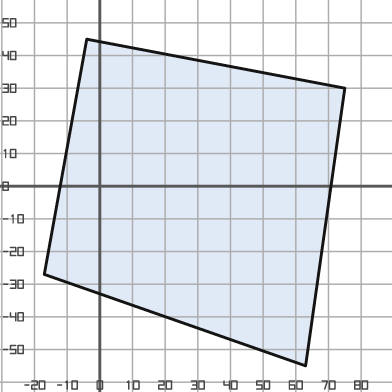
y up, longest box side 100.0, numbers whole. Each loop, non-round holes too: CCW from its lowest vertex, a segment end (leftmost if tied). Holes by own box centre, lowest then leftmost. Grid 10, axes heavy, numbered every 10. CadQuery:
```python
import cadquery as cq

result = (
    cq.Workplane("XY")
    .moveTo(63.0, -55.0)
    .lineTo(75.0, 30.0)
    .lineTo(-4.0, 45.0)
    .lineTo(-17.0, -27.0)
    .close()
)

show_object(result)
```